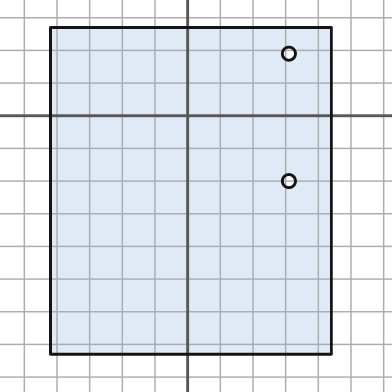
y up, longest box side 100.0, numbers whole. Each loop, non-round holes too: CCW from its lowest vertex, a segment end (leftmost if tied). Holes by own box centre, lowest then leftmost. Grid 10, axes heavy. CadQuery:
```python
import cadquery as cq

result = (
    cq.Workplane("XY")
    .moveTo(-42.0, -73.0)
    .lineTo(44.0, -73.0)
    .lineTo(44.0, 27.0)
    .lineTo(-42.0, 27.0)
    .close()
    .moveTo(31.0, -20.0)
    .circle(2.0)
    .moveTo(31.0, 19.0)
    .circle(2.0)
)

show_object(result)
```